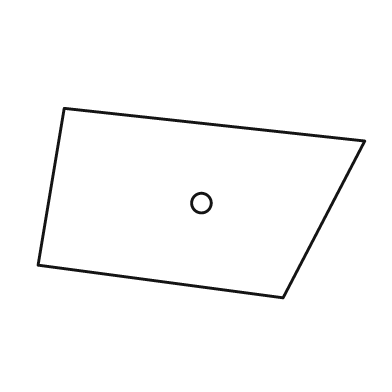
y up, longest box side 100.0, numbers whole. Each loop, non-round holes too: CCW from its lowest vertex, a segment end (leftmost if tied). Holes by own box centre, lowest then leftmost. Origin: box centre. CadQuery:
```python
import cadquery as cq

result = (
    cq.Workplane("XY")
    .moveTo(25.0, -29.0)
    .lineTo(50.0, 19.0)
    .lineTo(-42.0, 29.0)
    .lineTo(-50.0, -19.0)
    .close()
    .moveTo(0.0, 0.0)
    .circle(3.0)
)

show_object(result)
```